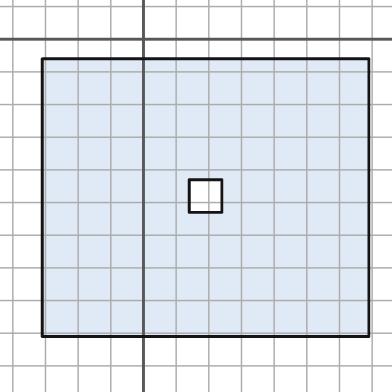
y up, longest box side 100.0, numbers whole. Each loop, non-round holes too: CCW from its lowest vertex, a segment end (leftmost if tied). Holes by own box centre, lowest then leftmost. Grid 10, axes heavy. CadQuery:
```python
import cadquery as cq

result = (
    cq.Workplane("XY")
    .moveTo(-31.0, -91.0)
    .lineTo(69.0, -91.0)
    .lineTo(69.0, -6.0)
    .lineTo(-31.0, -6.0)
    .close()
    .moveTo(14.0, -53.0)
    .lineTo(24.0, -53.0)
    .lineTo(24.0, -43.0)
    .lineTo(14.0, -43.0)
    .close()
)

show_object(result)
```